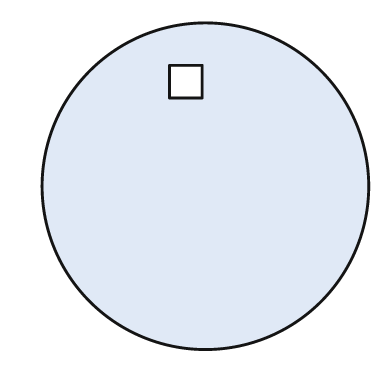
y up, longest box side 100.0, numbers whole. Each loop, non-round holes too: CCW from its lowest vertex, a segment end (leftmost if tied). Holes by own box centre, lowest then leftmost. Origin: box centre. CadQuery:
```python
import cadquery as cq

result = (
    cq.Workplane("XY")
    .moveTo(0.0, 0.0)
    .circle(50.0)
    .moveTo(-11.0, 27.0)
    .lineTo(-1.0, 27.0)
    .lineTo(-1.0, 37.0)
    .lineTo(-11.0, 37.0)
    .close()
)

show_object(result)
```